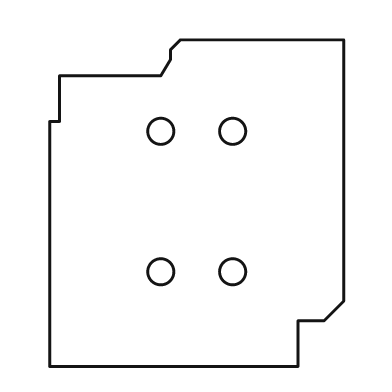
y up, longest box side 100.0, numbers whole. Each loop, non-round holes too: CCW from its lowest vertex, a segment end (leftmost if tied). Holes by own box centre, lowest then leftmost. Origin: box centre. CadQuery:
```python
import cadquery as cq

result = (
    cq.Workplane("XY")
    .moveTo(-45.0, -50.0)
    .lineTo(31.0, -50.0)
    .lineTo(31.0, -36.0)
    .lineTo(39.0, -36.0)
    .lineTo(45.0, -30.0)
    .lineTo(45.0, 50.0)
    .lineTo(-5.0, 50.0)
    .lineTo(-8.0, 47.0)
    .lineTo(-8.0, 44.0)
    .lineTo(-11.0, 39.0)
    .lineTo(-42.0, 39.0)
    .lineTo(-42.0, 25.0)
    .lineTo(-45.0, 25.0)
    .close()
    .moveTo(-11.0, -21.0)
    .circle(4.0)
    .moveTo(11.0, -21.0)
    .circle(4.0)
    .moveTo(-11.0, 22.0)
    .circle(4.0)
    .moveTo(11.0, 22.0)
    .circle(4.0)
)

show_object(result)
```